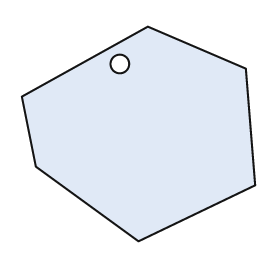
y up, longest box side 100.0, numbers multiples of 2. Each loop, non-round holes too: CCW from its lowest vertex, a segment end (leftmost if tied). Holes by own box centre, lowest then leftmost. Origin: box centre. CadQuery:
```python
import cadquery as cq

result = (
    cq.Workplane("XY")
    .moveTo(0.0, -46.0)
    .lineTo(50.0, -22.0)
    .lineTo(46.0, 28.0)
    .lineTo(4.0, 46.0)
    .lineTo(-50.0, 16.0)
    .lineTo(-44.0, -14.0)
    .close()
    .moveTo(-8.0, 30.0)
    .circle(4.0)
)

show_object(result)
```